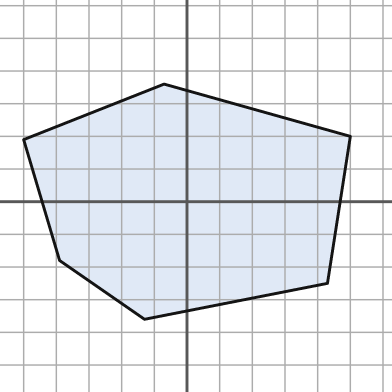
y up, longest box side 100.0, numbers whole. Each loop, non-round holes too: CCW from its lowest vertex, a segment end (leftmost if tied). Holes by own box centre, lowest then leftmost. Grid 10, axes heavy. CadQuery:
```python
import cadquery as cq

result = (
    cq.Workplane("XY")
    .moveTo(-13.0, -36.0)
    .lineTo(43.0, -25.0)
    .lineTo(50.0, 20.0)
    .lineTo(-7.0, 36.0)
    .lineTo(-50.0, 19.0)
    .lineTo(-39.0, -18.0)
    .close()
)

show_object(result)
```